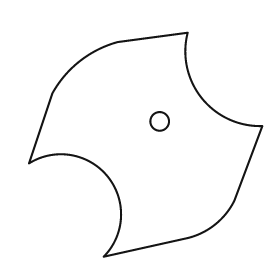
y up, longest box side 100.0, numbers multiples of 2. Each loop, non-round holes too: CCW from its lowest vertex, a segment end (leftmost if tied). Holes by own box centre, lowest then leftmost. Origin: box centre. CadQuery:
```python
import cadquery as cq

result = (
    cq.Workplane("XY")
    .moveTo(-18.0, -48.0)
    .lineTo(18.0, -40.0)
    .threePointArc((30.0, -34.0), (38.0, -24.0))
    .lineTo(50.0, 8.0)
    .threePointArc((24.0, 20.0), (18.0, 48.0))
    .lineTo(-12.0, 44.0)
    .threePointArc((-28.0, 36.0), (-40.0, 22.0))
    .lineTo(-50.0, -8.0)
    .threePointArc((-16.0, -14.0), (-18.0, -48.0))
    .close()
    .moveTo(6.0, 10.0)
    .circle(4.0)
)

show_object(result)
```